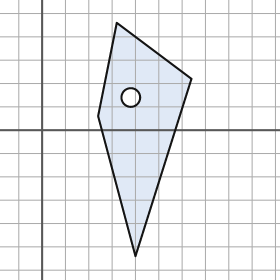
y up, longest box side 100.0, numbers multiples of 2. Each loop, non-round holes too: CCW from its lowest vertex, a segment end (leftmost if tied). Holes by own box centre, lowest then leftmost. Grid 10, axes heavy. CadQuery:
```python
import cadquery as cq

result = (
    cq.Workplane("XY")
    .moveTo(40.0, -54.0)
    .lineTo(64.0, 22.0)
    .lineTo(32.0, 46.0)
    .lineTo(24.0, 6.0)
    .close()
    .moveTo(38.0, 14.0)
    .circle(4.0)
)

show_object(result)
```